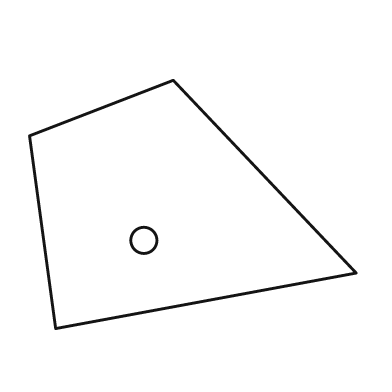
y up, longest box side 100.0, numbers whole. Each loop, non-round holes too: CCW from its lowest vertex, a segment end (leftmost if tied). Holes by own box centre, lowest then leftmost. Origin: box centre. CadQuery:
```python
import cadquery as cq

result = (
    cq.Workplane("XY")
    .moveTo(-42.0, -38.0)
    .lineTo(50.0, -21.0)
    .lineTo(-6.0, 38.0)
    .lineTo(-50.0, 21.0)
    .close()
    .moveTo(-15.0, -11.0)
    .circle(4.0)
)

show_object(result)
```